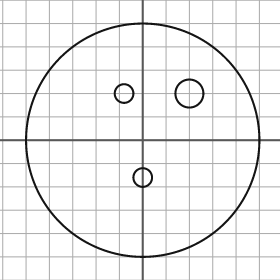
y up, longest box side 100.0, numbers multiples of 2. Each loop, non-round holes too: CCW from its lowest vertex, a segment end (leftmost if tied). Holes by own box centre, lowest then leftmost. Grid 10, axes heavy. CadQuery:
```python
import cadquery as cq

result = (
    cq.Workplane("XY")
    .moveTo(0.0, 0.0)
    .circle(50.0)
    .moveTo(0.0, -16.0)
    .circle(4.0)
    .moveTo(-8.0, 20.0)
    .circle(4.0)
    .moveTo(20.0, 20.0)
    .circle(6.0)
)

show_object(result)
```